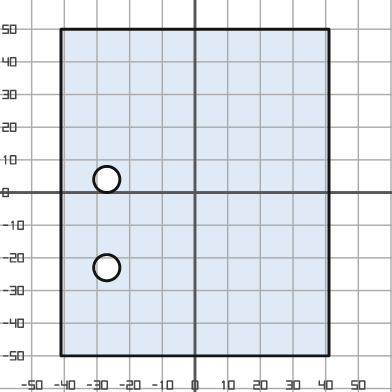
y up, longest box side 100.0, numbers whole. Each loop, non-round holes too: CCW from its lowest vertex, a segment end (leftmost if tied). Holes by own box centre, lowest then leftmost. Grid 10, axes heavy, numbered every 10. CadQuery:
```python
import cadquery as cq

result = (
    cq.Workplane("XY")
    .moveTo(-41.0, -50.0)
    .lineTo(41.0, -50.0)
    .lineTo(41.0, 50.0)
    .lineTo(-41.0, 50.0)
    .close()
    .moveTo(-27.0, -23.0)
    .circle(4.0)
    .moveTo(-27.0, 4.0)
    .circle(4.0)
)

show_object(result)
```